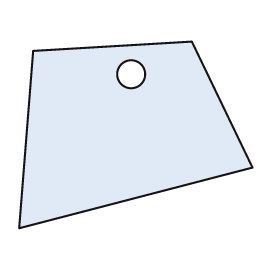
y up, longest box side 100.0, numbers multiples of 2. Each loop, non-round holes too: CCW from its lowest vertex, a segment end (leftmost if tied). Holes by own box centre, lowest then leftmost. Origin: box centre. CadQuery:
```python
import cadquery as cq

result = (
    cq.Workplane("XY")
    .moveTo(-50.0, -40.0)
    .lineTo(50.0, -14.0)
    .lineTo(24.0, 40.0)
    .lineTo(-44.0, 36.0)
    .close()
    .moveTo(-2.0, 26.0)
    .circle(6.0)
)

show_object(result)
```